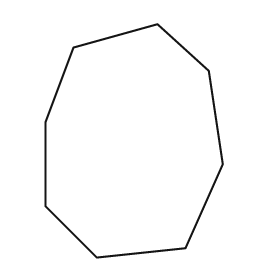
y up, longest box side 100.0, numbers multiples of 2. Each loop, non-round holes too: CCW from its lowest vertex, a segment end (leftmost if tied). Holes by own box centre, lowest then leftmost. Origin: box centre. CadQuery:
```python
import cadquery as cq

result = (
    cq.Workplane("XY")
    .moveTo(-16.0, -50.0)
    .lineTo(22.0, -46.0)
    .lineTo(38.0, -10.0)
    .lineTo(32.0, 30.0)
    .lineTo(10.0, 50.0)
    .lineTo(-26.0, 40.0)
    .lineTo(-38.0, 8.0)
    .lineTo(-38.0, -28.0)
    .close()
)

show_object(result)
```